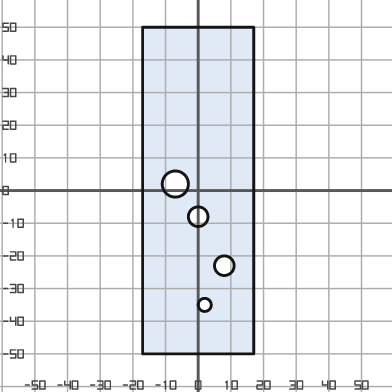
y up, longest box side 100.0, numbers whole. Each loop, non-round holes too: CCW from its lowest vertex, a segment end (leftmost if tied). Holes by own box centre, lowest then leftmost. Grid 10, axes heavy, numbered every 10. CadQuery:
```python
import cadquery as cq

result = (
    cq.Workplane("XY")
    .moveTo(-17.0, -50.0)
    .lineTo(17.0, -50.0)
    .lineTo(17.0, 50.0)
    .lineTo(-17.0, 50.0)
    .close()
    .moveTo(2.0, -35.0)
    .circle(2.0)
    .moveTo(8.0, -23.0)
    .circle(3.0)
    .moveTo(0.0, -8.0)
    .circle(3.0)
    .moveTo(-7.0, 2.0)
    .circle(4.0)
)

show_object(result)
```